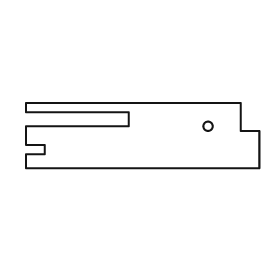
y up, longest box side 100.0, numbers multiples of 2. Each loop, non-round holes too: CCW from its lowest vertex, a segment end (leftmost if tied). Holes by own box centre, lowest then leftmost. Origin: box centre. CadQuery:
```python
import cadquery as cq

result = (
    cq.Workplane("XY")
    .moveTo(-50.0, -14.0)
    .lineTo(50.0, -14.0)
    .lineTo(50.0, 2.0)
    .lineTo(42.0, 2.0)
    .lineTo(42.0, 14.0)
    .lineTo(-50.0, 14.0)
    .lineTo(-50.0, 10.0)
    .lineTo(-6.0, 10.0)
    .lineTo(-6.0, 4.0)
    .lineTo(-50.0, 4.0)
    .lineTo(-50.0, -4.0)
    .lineTo(-42.0, -4.0)
    .lineTo(-42.0, -8.0)
    .lineTo(-50.0, -8.0)
    .close()
    .moveTo(28.0, 4.0)
    .circle(2.0)
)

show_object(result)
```